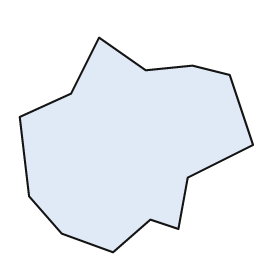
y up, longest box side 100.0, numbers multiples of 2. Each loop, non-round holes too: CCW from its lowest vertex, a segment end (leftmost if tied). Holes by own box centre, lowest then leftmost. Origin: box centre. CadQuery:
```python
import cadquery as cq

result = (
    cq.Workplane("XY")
    .moveTo(-10.0, -46.0)
    .lineTo(6.0, -32.0)
    .lineTo(18.0, -36.0)
    .lineTo(22.0, -14.0)
    .lineTo(50.0, 0.0)
    .lineTo(40.0, 30.0)
    .lineTo(24.0, 34.0)
    .lineTo(4.0, 32.0)
    .lineTo(-16.0, 46.0)
    .lineTo(-28.0, 22.0)
    .lineTo(-50.0, 12.0)
    .lineTo(-46.0, -22.0)
    .lineTo(-32.0, -38.0)
    .close()
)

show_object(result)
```